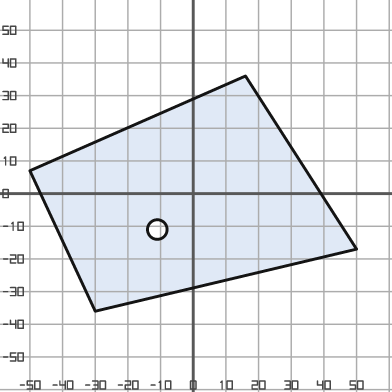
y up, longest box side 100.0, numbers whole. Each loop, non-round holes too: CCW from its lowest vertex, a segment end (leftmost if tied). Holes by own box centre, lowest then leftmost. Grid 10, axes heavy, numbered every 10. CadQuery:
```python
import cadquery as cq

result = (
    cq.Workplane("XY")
    .moveTo(-30.0, -36.0)
    .lineTo(50.0, -17.0)
    .lineTo(16.0, 36.0)
    .lineTo(-50.0, 7.0)
    .close()
    .moveTo(-11.0, -11.0)
    .circle(3.0)
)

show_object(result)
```